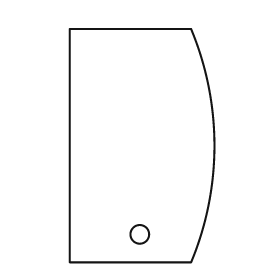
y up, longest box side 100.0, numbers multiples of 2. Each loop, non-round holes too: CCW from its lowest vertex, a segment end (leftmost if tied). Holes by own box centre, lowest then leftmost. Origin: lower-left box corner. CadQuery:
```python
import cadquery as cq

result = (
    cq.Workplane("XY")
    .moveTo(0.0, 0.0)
    .lineTo(52.0, 0.0)
    .threePointArc((62.0, 50.0), (52.0, 100.0))
    .lineTo(0.0, 100.0)
    .close()
    .moveTo(30.0, 12.0)
    .circle(4.0)
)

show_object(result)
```